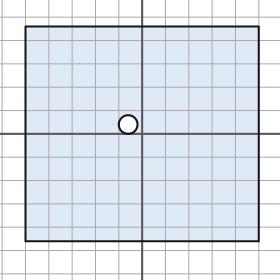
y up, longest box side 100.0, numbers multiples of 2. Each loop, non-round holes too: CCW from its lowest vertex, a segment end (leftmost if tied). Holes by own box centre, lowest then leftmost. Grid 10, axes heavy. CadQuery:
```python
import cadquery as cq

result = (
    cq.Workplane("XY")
    .moveTo(-50.0, -46.0)
    .lineTo(50.0, -46.0)
    .lineTo(50.0, 46.0)
    .lineTo(-50.0, 46.0)
    .close()
    .moveTo(-6.0, 4.0)
    .circle(4.0)
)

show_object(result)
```